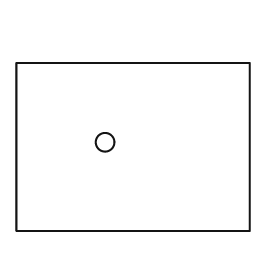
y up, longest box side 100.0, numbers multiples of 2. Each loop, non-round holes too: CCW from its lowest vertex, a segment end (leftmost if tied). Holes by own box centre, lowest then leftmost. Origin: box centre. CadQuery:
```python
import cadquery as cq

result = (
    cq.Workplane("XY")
    .moveTo(-50.0, -36.0)
    .lineTo(50.0, -36.0)
    .lineTo(50.0, 36.0)
    .lineTo(-50.0, 36.0)
    .close()
    .moveTo(-12.0, 2.0)
    .circle(4.0)
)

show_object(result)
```